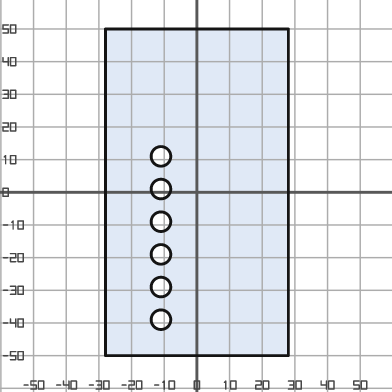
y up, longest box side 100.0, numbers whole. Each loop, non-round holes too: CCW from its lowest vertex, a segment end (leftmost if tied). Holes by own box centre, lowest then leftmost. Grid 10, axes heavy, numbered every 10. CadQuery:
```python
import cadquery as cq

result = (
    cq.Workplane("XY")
    .moveTo(-28.0, -50.0)
    .lineTo(28.0, -50.0)
    .lineTo(28.0, 50.0)
    .lineTo(-28.0, 50.0)
    .close()
    .moveTo(-11.0, -39.0)
    .circle(3.0)
    .moveTo(-11.0, -29.0)
    .circle(3.0)
    .moveTo(-11.0, -19.0)
    .circle(3.0)
    .moveTo(-11.0, -9.0)
    .circle(3.0)
    .moveTo(-11.0, 1.0)
    .circle(3.0)
    .moveTo(-11.0, 11.0)
    .circle(3.0)
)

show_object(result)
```